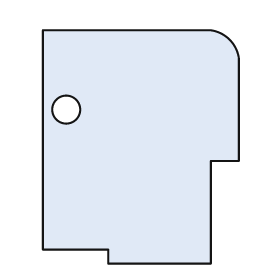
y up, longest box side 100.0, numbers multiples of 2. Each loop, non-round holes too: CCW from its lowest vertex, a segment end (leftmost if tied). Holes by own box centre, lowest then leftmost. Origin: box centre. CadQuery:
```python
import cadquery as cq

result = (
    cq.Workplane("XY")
    .moveTo(-14.0, -50.0)
    .lineTo(30.0, -50.0)
    .lineTo(30.0, -6.0)
    .lineTo(42.0, -6.0)
    .lineTo(42.0, 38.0)
    .threePointArc((38.0, 46.0), (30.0, 50.0))
    .lineTo(-42.0, 50.0)
    .lineTo(-42.0, -44.0)
    .lineTo(-14.0, -44.0)
    .close()
    .moveTo(-32.0, 16.0)
    .circle(6.0)
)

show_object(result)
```